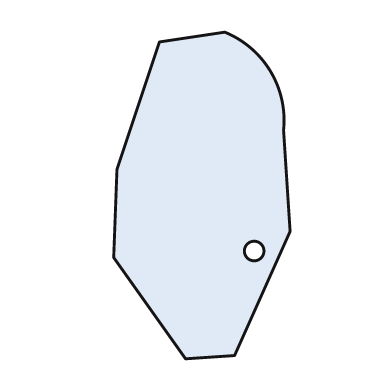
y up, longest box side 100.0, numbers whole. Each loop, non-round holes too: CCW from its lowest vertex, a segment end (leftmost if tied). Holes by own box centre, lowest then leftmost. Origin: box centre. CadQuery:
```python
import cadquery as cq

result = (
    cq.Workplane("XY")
    .moveTo(-5.0, -50.0)
    .lineTo(10.0, -49.0)
    .lineTo(27.0, -11.0)
    .lineTo(25.0, 20.0)
    .threePointArc((21.0, 38.0), (7.0, 50.0))
    .lineTo(-13.0, 47.0)
    .lineTo(-26.0, 8.0)
    .lineTo(-27.0, -19.0)
    .close()
    .moveTo(16.0, -17.0)
    .circle(3.0)
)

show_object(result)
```